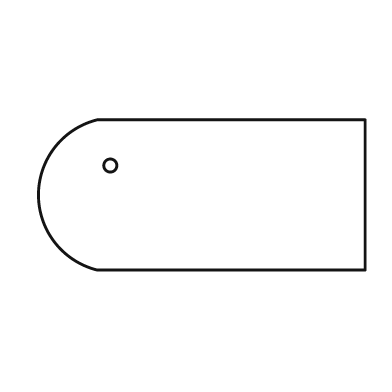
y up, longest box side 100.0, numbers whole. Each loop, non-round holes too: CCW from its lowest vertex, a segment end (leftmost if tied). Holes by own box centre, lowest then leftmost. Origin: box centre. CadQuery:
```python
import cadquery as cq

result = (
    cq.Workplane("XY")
    .moveTo(-32.0, -23.0)
    .lineTo(50.0, -23.0)
    .lineTo(50.0, 23.0)
    .lineTo(-32.0, 23.0)
    .threePointArc((-50.0, 0.0), (-32.0, -23.0))
    .close()
    .moveTo(-28.0, 9.0)
    .circle(2.0)
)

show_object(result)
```